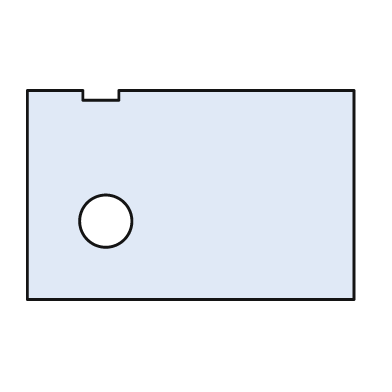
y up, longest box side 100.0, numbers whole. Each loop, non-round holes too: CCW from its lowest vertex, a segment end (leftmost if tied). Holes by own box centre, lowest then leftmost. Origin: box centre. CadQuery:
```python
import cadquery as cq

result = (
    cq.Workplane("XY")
    .moveTo(-50.0, -32.0)
    .lineTo(50.0, -32.0)
    .lineTo(50.0, 32.0)
    .lineTo(-22.0, 32.0)
    .lineTo(-22.0, 29.0)
    .lineTo(-33.0, 29.0)
    .lineTo(-33.0, 32.0)
    .lineTo(-50.0, 32.0)
    .close()
    .moveTo(-26.0, -8.0)
    .circle(8.0)
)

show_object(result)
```